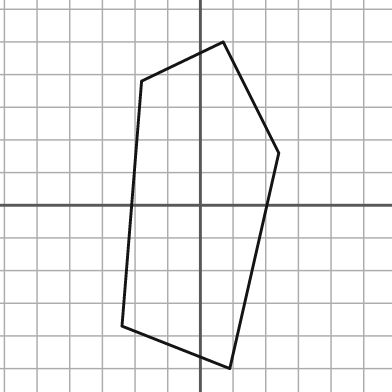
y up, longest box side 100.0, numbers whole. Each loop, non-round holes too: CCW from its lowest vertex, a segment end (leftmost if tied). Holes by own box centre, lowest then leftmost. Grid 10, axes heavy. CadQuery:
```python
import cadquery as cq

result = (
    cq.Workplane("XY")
    .moveTo(9.0, -50.0)
    .lineTo(24.0, 16.0)
    .lineTo(7.0, 50.0)
    .lineTo(-18.0, 38.0)
    .lineTo(-24.0, -37.0)
    .close()
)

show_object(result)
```